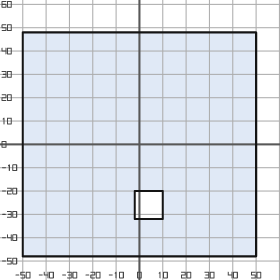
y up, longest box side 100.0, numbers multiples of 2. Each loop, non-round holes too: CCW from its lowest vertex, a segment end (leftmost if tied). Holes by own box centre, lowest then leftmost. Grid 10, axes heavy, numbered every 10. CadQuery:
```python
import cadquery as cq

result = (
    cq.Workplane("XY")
    .moveTo(-50.0, -48.0)
    .lineTo(50.0, -48.0)
    .lineTo(50.0, 48.0)
    .lineTo(-50.0, 48.0)
    .close()
    .moveTo(-2.0, -32.0)
    .lineTo(10.0, -32.0)
    .lineTo(10.0, -20.0)
    .lineTo(-2.0, -20.0)
    .close()
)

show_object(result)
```